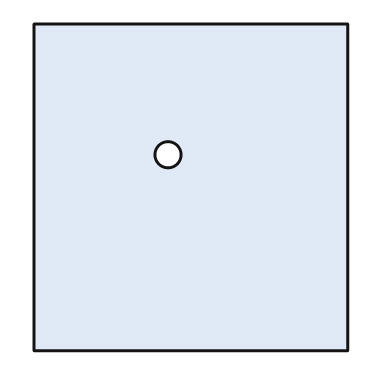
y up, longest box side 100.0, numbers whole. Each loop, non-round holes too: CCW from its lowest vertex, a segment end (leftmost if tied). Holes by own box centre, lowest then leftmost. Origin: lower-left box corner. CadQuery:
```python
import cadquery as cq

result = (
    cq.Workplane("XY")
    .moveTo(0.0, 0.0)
    .lineTo(96.0, 0.0)
    .lineTo(96.0, 100.0)
    .lineTo(0.0, 100.0)
    .close()
    .moveTo(41.0, 60.0)
    .circle(4.0)
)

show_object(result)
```